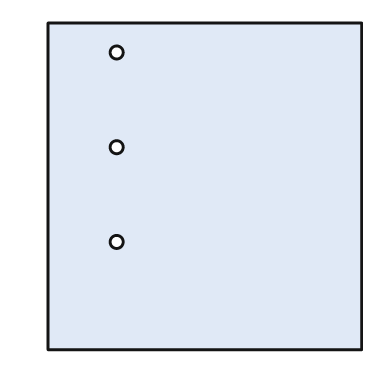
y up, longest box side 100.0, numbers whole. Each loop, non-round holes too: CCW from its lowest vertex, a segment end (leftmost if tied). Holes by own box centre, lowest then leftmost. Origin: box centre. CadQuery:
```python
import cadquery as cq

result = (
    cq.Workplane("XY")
    .moveTo(-48.0, -50.0)
    .lineTo(48.0, -50.0)
    .lineTo(48.0, 50.0)
    .lineTo(-48.0, 50.0)
    .close()
    .moveTo(-27.0, -17.0)
    .circle(2.0)
    .moveTo(-27.0, 12.0)
    .circle(2.0)
    .moveTo(-27.0, 41.0)
    .circle(2.0)
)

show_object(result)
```